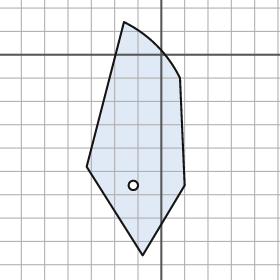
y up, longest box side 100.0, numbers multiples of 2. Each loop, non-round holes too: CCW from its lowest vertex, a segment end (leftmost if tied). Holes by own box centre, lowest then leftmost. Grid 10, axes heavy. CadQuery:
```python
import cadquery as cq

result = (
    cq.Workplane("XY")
    .moveTo(-8.0, -86.0)
    .lineTo(10.0, -56.0)
    .lineTo(8.0, -10.0)
    .threePointArc((-2.0, 4.0), (-16.0, 14.0))
    .lineTo(-32.0, -48.0)
    .close()
    .moveTo(-12.0, -56.0)
    .circle(2.0)
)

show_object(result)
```